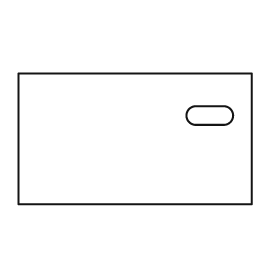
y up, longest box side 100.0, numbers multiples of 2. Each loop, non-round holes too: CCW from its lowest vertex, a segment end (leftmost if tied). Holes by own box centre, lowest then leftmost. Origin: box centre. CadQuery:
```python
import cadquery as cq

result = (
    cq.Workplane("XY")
    .moveTo(-50.0, -28.0)
    .lineTo(50.0, -28.0)
    .lineTo(50.0, 28.0)
    .lineTo(-50.0, 28.0)
    .close()
    .moveTo(26.0, 6.0)
    .lineTo(38.0, 6.0)
    .threePointArc((42.0, 10.0), (38.0, 14.0))
    .lineTo(26.0, 14.0)
    .threePointArc((22.0, 10.0), (26.0, 6.0))
    .close()
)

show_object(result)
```